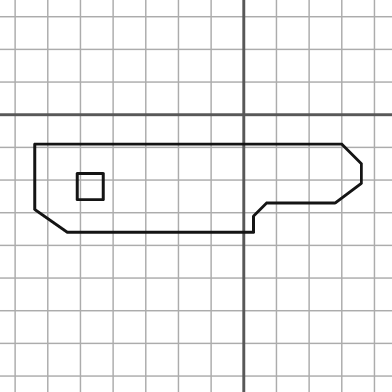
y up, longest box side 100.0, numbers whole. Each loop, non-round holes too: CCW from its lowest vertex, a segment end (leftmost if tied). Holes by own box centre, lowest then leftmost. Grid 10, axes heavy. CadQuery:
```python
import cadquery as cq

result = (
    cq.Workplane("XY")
    .moveTo(-54.0, -36.0)
    .lineTo(3.0, -36.0)
    .lineTo(3.0, -31.0)
    .lineTo(7.0, -27.0)
    .lineTo(28.0, -27.0)
    .lineTo(36.0, -21.0)
    .lineTo(36.0, -15.0)
    .lineTo(30.0, -9.0)
    .lineTo(-64.0, -9.0)
    .lineTo(-64.0, -29.0)
    .close()
    .moveTo(-51.0, -26.0)
    .lineTo(-43.0, -26.0)
    .lineTo(-43.0, -18.0)
    .lineTo(-51.0, -18.0)
    .close()
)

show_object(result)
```